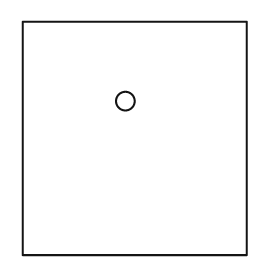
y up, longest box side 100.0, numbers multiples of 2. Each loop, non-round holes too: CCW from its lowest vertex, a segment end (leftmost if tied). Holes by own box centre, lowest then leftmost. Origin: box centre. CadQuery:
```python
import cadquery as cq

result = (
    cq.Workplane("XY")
    .moveTo(-48.0, -50.0)
    .lineTo(48.0, -50.0)
    .lineTo(48.0, 50.0)
    .lineTo(-48.0, 50.0)
    .close()
    .moveTo(-4.0, 16.0)
    .circle(4.0)
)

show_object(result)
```